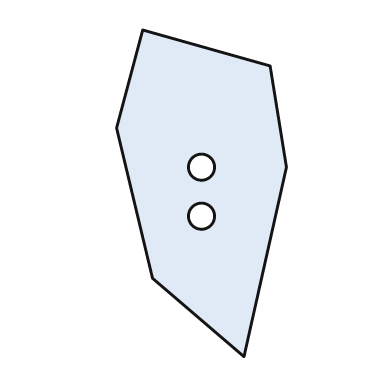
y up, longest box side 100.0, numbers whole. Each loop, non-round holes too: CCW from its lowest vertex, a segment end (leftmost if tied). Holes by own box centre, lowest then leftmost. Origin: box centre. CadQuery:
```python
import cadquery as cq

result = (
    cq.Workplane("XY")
    .moveTo(13.0, -50.0)
    .lineTo(26.0, 8.0)
    .lineTo(21.0, 39.0)
    .lineTo(-18.0, 50.0)
    .lineTo(-26.0, 20.0)
    .lineTo(-15.0, -26.0)
    .close()
    .moveTo(0.0, -7.0)
    .circle(4.0)
    .moveTo(0.0, 8.0)
    .circle(4.0)
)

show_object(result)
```